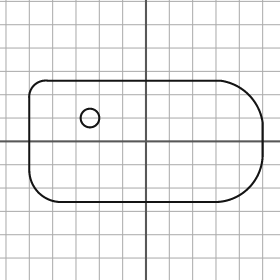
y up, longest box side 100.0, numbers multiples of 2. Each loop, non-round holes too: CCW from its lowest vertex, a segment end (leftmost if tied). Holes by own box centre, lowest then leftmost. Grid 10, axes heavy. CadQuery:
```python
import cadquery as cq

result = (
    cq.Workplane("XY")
    .moveTo(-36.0, -26.0)
    .lineTo(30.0, -26.0)
    .threePointArc((44.0, -20.0), (50.0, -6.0))
    .lineTo(50.0, 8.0)
    .threePointArc((44.0, 20.0), (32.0, 26.0))
    .lineTo(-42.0, 26.0)
    .threePointArc((-48.0, 24.0), (-50.0, 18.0))
    .lineTo(-50.0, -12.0)
    .threePointArc((-46.0, -22.0), (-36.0, -26.0))
    .close()
    .moveTo(-24.0, 10.0)
    .circle(4.0)
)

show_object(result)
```